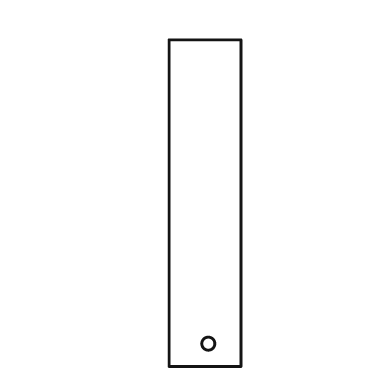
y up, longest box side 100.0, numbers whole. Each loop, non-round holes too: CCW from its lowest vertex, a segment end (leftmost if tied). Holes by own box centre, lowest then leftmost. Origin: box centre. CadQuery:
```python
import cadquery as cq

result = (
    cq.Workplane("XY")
    .moveTo(-11.0, -50.0)
    .lineTo(11.0, -50.0)
    .lineTo(11.0, 50.0)
    .lineTo(-11.0, 50.0)
    .close()
    .moveTo(1.0, -43.0)
    .circle(2.0)
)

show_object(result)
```